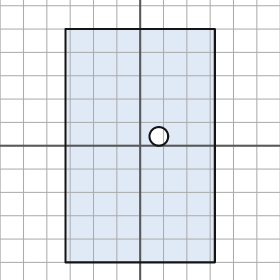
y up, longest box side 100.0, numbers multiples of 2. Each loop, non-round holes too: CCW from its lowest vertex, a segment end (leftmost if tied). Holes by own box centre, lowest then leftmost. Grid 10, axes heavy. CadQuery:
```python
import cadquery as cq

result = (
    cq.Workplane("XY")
    .moveTo(-32.0, -50.0)
    .lineTo(32.0, -50.0)
    .lineTo(32.0, 50.0)
    .lineTo(-32.0, 50.0)
    .close()
    .moveTo(8.0, 4.0)
    .circle(4.0)
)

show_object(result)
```